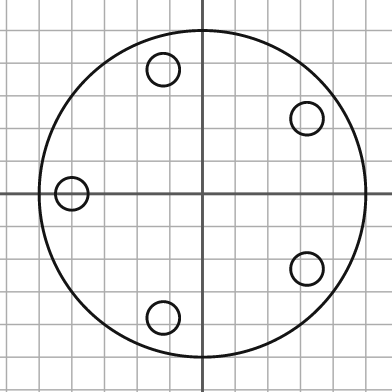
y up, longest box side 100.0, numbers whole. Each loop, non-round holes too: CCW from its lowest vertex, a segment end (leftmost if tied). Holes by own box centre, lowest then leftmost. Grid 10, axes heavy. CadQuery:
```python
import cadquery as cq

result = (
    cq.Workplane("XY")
    .moveTo(0.0, 0.0)
    .circle(50.0)
    .moveTo(-12.0, -38.0)
    .circle(5.0)
    .moveTo(32.0, -23.0)
    .circle(5.0)
    .moveTo(-40.0, 0.0)
    .circle(5.0)
    .moveTo(32.0, 23.0)
    .circle(5.0)
    .moveTo(-12.0, 38.0)
    .circle(5.0)
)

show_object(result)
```